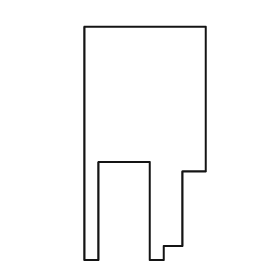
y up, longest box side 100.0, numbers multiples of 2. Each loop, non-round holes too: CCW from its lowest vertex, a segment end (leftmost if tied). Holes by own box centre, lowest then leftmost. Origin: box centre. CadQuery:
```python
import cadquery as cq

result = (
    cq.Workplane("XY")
    .moveTo(-26.0, -50.0)
    .lineTo(-20.0, -50.0)
    .lineTo(-20.0, -8.0)
    .lineTo(2.0, -8.0)
    .lineTo(2.0, -50.0)
    .lineTo(8.0, -50.0)
    .lineTo(8.0, -44.0)
    .lineTo(16.0, -44.0)
    .lineTo(16.0, -12.0)
    .lineTo(26.0, -12.0)
    .lineTo(26.0, 50.0)
    .lineTo(-26.0, 50.0)
    .close()
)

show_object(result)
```